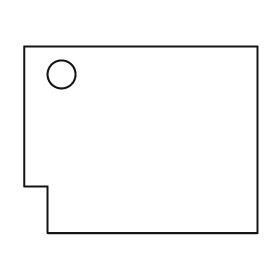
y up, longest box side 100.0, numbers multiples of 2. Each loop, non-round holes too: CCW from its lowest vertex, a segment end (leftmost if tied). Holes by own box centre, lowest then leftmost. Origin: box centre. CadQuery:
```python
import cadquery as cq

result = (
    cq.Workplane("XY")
    .moveTo(-40.0, -40.0)
    .lineTo(50.0, -40.0)
    .lineTo(50.0, 40.0)
    .lineTo(-50.0, 40.0)
    .lineTo(-50.0, -20.0)
    .lineTo(-40.0, -20.0)
    .close()
    .moveTo(-34.0, 28.0)
    .circle(6.0)
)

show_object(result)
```